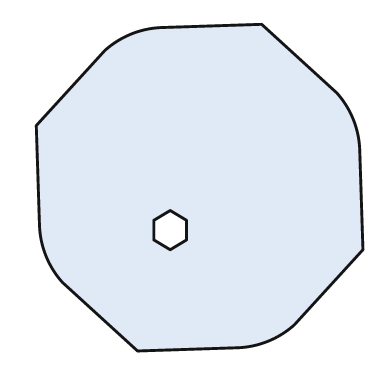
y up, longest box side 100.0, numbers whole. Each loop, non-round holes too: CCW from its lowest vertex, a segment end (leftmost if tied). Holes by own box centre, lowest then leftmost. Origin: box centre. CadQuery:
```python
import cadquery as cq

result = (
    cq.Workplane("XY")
    .moveTo(-19.0, -50.0)
    .lineTo(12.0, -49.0)
    .threePointArc((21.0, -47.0), (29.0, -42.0))
    .lineTo(50.0, -19.0)
    .lineTo(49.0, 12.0)
    .threePointArc((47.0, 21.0), (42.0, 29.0))
    .lineTo(19.0, 50.0)
    .lineTo(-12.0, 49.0)
    .threePointArc((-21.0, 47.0), (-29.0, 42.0))
    .lineTo(-50.0, 19.0)
    .lineTo(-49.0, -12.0)
    .threePointArc((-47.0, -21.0), (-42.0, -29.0))
    .close()
    .moveTo(-9.0, -19.0)
    .lineTo(-4.0, -16.0)
    .lineTo(-4.0, -10.0)
    .lineTo(-9.0, -7.0)
    .lineTo(-14.0, -10.0)
    .lineTo(-14.0, -16.0)
    .close()
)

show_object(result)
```